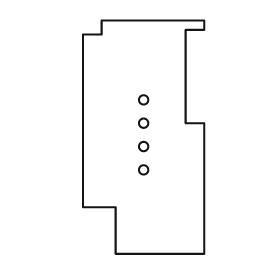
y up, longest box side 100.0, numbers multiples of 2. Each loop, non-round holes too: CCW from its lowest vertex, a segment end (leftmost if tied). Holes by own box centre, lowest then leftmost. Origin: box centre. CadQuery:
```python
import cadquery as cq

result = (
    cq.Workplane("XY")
    .moveTo(-12.0, -50.0)
    .lineTo(26.0, -50.0)
    .lineTo(26.0, 6.0)
    .lineTo(18.0, 6.0)
    .lineTo(18.0, 46.0)
    .lineTo(26.0, 46.0)
    .lineTo(26.0, 50.0)
    .lineTo(-18.0, 50.0)
    .lineTo(-18.0, 44.0)
    .lineTo(-26.0, 44.0)
    .lineTo(-26.0, -30.0)
    .lineTo(-12.0, -30.0)
    .close()
    .moveTo(0.0, -14.0)
    .circle(2.0)
    .moveTo(0.0, -4.0)
    .circle(2.0)
    .moveTo(0.0, 6.0)
    .circle(2.0)
    .moveTo(0.0, 16.0)
    .circle(2.0)
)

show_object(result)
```